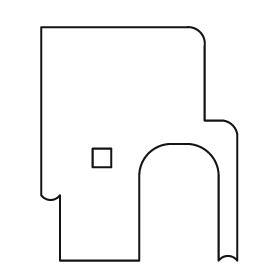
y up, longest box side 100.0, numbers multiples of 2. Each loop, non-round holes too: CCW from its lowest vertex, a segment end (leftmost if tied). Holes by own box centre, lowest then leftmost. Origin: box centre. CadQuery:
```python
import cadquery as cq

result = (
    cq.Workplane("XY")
    .moveTo(-34.0, -50.0)
    .lineTo(0.0, -50.0)
    .lineTo(0.0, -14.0)
    .threePointArc((4.0, -4.0), (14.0, 0.0))
    .lineTo(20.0, 0.0)
    .threePointArc((30.0, -4.0), (34.0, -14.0))
    .lineTo(34.0, -50.0)
    .threePointArc((38.0, -48.0), (42.0, -50.0))
    .lineTo(42.0, 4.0)
    .threePointArc((40.0, 8.0), (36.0, 10.0))
    .lineTo(28.0, 10.0)
    .lineTo(28.0, 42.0)
    .threePointArc((26.0, 48.0), (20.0, 50.0))
    .lineTo(-42.0, 50.0)
    .lineTo(-42.0, -22.0)
    .threePointArc((-38.0, -24.0), (-34.0, -22.0))
    .close()
    .moveTo(-20.0, -10.0)
    .lineTo(-12.0, -10.0)
    .lineTo(-12.0, -2.0)
    .lineTo(-20.0, -2.0)
    .close()
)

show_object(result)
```